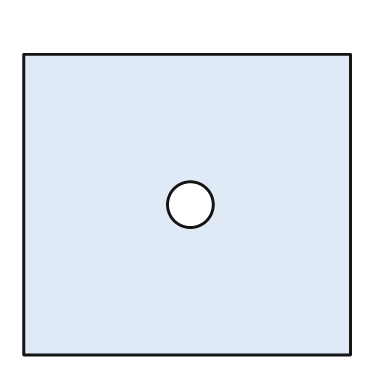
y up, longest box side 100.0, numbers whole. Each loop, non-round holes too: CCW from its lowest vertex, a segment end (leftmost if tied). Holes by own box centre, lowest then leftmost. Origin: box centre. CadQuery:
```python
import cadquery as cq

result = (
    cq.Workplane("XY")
    .moveTo(-50.0, -46.0)
    .lineTo(50.0, -46.0)
    .lineTo(50.0, 46.0)
    .lineTo(-50.0, 46.0)
    .close()
    .moveTo(1.0, 0.0)
    .circle(7.0)
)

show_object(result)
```